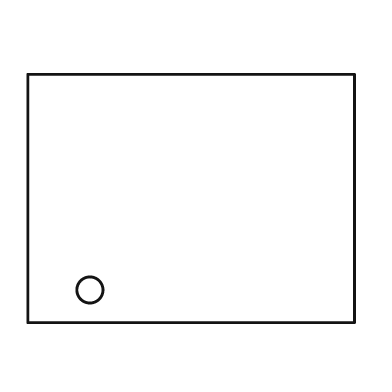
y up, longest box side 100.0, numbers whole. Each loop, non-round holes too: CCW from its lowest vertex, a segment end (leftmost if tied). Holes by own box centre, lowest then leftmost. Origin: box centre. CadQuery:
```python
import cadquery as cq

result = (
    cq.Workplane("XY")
    .moveTo(-50.0, -38.0)
    .lineTo(50.0, -38.0)
    .lineTo(50.0, 38.0)
    .lineTo(-50.0, 38.0)
    .close()
    .moveTo(-31.0, -28.0)
    .circle(4.0)
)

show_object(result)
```